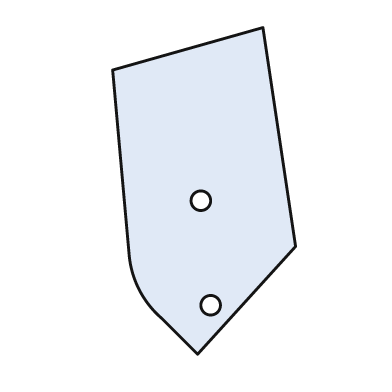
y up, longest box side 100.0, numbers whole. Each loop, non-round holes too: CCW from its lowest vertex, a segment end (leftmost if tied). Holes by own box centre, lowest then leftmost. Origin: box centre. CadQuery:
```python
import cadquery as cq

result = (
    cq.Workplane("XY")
    .moveTo(-2.0, -50.0)
    .lineTo(28.0, -17.0)
    .lineTo(18.0, 50.0)
    .lineTo(-28.0, 37.0)
    .lineTo(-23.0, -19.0)
    .threePointArc((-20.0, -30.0), (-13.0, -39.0))
    .close()
    .moveTo(2.0, -35.0)
    .circle(3.0)
    .moveTo(-1.0, -3.0)
    .circle(3.0)
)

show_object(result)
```